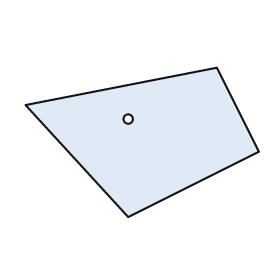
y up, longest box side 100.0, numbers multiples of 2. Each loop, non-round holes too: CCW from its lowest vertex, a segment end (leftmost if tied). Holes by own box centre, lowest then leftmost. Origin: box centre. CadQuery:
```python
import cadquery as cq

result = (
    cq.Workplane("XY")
    .moveTo(-6.0, -32.0)
    .lineTo(50.0, -4.0)
    .lineTo(32.0, 32.0)
    .lineTo(-50.0, 16.0)
    .close()
    .moveTo(-6.0, 10.0)
    .circle(2.0)
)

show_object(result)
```